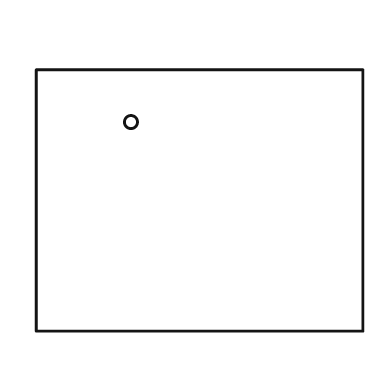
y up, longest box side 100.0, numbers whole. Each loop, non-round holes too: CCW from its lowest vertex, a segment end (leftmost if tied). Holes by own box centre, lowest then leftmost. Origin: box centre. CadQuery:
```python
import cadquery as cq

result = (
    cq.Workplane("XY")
    .moveTo(-50.0, -40.0)
    .lineTo(50.0, -40.0)
    .lineTo(50.0, 40.0)
    .lineTo(-50.0, 40.0)
    .close()
    .moveTo(-21.0, 24.0)
    .circle(2.0)
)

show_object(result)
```